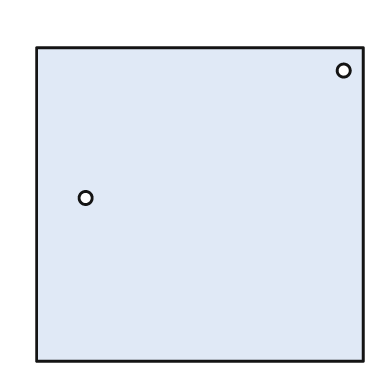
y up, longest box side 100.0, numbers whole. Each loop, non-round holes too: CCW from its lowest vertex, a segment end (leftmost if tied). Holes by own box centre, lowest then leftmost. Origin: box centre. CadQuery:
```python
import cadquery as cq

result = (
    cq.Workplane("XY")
    .moveTo(-50.0, -48.0)
    .lineTo(50.0, -48.0)
    .lineTo(50.0, 48.0)
    .lineTo(-50.0, 48.0)
    .close()
    .moveTo(-35.0, 2.0)
    .circle(2.0)
    .moveTo(44.0, 41.0)
    .circle(2.0)
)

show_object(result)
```